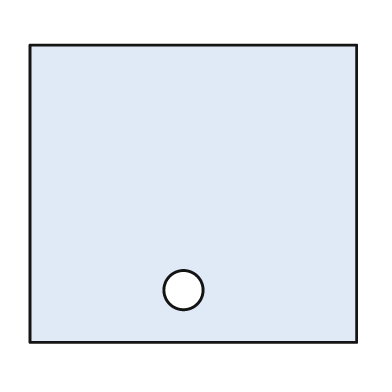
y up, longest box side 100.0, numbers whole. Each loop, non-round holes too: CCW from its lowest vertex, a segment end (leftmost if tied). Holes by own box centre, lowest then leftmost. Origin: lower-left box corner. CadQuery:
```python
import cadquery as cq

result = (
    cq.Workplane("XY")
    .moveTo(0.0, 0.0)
    .lineTo(100.0, 0.0)
    .lineTo(100.0, 91.0)
    .lineTo(0.0, 91.0)
    .close()
    .moveTo(47.0, 16.0)
    .circle(6.0)
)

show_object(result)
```